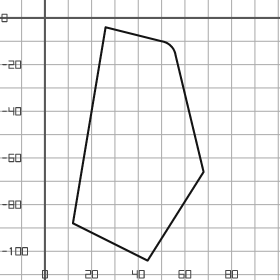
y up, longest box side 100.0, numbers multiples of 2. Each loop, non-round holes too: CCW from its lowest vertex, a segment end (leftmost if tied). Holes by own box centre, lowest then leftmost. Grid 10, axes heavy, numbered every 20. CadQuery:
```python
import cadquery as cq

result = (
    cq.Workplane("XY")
    .moveTo(44.0, -104.0)
    .lineTo(68.0, -66.0)
    .lineTo(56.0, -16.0)
    .threePointArc((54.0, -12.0), (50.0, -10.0))
    .lineTo(26.0, -4.0)
    .lineTo(12.0, -88.0)
    .close()
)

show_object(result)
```